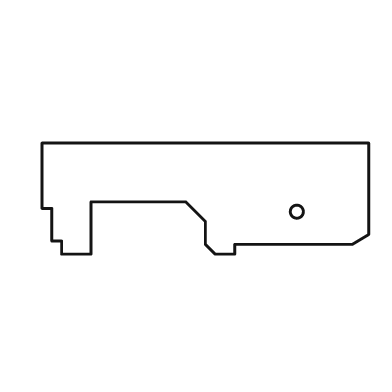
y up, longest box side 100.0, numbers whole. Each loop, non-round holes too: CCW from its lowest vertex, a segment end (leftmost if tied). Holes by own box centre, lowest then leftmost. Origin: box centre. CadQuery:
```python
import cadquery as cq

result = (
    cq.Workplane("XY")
    .moveTo(-44.0, -17.0)
    .lineTo(-35.0, -17.0)
    .lineTo(-35.0, -1.0)
    .lineTo(-6.0, -1.0)
    .lineTo(0.0, -7.0)
    .lineTo(0.0, -14.0)
    .lineTo(3.0, -17.0)
    .lineTo(9.0, -17.0)
    .lineTo(9.0, -14.0)
    .lineTo(45.0, -14.0)
    .lineTo(50.0, -11.0)
    .lineTo(50.0, 17.0)
    .lineTo(-50.0, 17.0)
    .lineTo(-50.0, -3.0)
    .lineTo(-47.0, -3.0)
    .lineTo(-47.0, -13.0)
    .lineTo(-44.0, -13.0)
    .close()
    .moveTo(28.0, -4.0)
    .circle(2.0)
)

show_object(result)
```